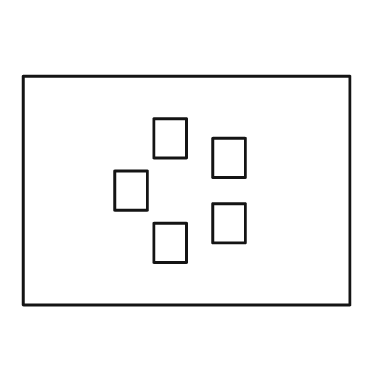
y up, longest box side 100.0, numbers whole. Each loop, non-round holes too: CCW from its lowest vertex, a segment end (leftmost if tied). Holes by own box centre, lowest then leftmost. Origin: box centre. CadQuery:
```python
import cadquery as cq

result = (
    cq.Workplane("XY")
    .moveTo(-50.0, -35.0)
    .lineTo(50.0, -35.0)
    .lineTo(50.0, 35.0)
    .lineTo(-50.0, 35.0)
    .close()
    .moveTo(-10.0, -22.0)
    .lineTo(0.0, -22.0)
    .lineTo(0.0, -10.0)
    .lineTo(-10.0, -10.0)
    .close()
    .moveTo(8.0, -16.0)
    .lineTo(18.0, -16.0)
    .lineTo(18.0, -4.0)
    .lineTo(8.0, -4.0)
    .close()
    .moveTo(-22.0, -6.0)
    .lineTo(-12.0, -6.0)
    .lineTo(-12.0, 6.0)
    .lineTo(-22.0, 6.0)
    .close()
    .moveTo(8.0, 4.0)
    .lineTo(18.0, 4.0)
    .lineTo(18.0, 16.0)
    .lineTo(8.0, 16.0)
    .close()
    .moveTo(-10.0, 10.0)
    .lineTo(0.0, 10.0)
    .lineTo(0.0, 22.0)
    .lineTo(-10.0, 22.0)
    .close()
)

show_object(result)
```